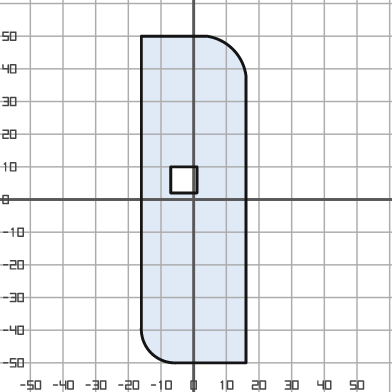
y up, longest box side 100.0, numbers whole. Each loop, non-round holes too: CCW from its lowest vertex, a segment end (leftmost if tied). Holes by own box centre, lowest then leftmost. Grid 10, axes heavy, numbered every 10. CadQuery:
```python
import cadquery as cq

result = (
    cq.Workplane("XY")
    .moveTo(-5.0, -50.0)
    .lineTo(16.0, -50.0)
    .lineTo(16.0, 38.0)
    .threePointArc((12.0, 46.0), (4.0, 50.0))
    .lineTo(-16.0, 50.0)
    .lineTo(-16.0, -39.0)
    .threePointArc((-13.0, -47.0), (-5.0, -50.0))
    .close()
    .moveTo(-7.0, 2.0)
    .lineTo(1.0, 2.0)
    .lineTo(1.0, 10.0)
    .lineTo(-7.0, 10.0)
    .close()
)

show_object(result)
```